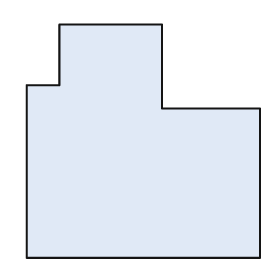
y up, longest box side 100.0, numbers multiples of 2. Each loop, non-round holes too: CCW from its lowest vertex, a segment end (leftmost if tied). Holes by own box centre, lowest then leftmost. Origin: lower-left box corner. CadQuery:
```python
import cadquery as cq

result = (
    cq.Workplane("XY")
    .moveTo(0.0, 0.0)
    .lineTo(100.0, 0.0)
    .lineTo(100.0, 64.0)
    .lineTo(58.0, 64.0)
    .lineTo(58.0, 100.0)
    .lineTo(14.0, 100.0)
    .lineTo(14.0, 74.0)
    .lineTo(0.0, 74.0)
    .close()
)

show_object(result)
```